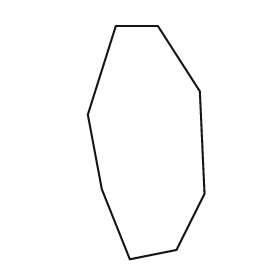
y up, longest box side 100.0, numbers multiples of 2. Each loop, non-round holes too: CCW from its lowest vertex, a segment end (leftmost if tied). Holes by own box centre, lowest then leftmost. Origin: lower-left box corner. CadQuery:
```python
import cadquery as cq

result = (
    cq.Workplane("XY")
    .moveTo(18.0, 0.0)
    .lineTo(38.0, 4.0)
    .lineTo(50.0, 28.0)
    .lineTo(48.0, 72.0)
    .lineTo(30.0, 100.0)
    .lineTo(12.0, 100.0)
    .lineTo(0.0, 62.0)
    .lineTo(6.0, 30.0)
    .close()
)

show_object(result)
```